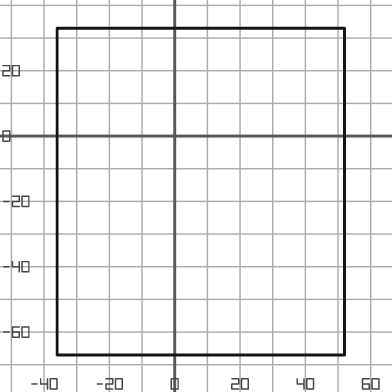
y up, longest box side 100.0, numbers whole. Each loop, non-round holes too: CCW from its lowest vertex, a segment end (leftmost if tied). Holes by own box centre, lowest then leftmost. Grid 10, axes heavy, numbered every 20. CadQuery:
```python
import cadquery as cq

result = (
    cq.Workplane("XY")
    .moveTo(-36.0, -67.0)
    .lineTo(52.0, -67.0)
    .lineTo(52.0, 33.0)
    .lineTo(-36.0, 33.0)
    .close()
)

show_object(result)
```